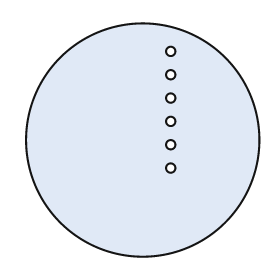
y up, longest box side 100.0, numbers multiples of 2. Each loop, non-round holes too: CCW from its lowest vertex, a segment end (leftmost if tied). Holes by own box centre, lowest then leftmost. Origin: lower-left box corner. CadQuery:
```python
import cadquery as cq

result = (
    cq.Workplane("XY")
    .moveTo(50.0, 50.0)
    .circle(50.0)
    .moveTo(62.0, 38.0)
    .circle(2.0)
    .moveTo(62.0, 48.0)
    .circle(2.0)
    .moveTo(62.0, 58.0)
    .circle(2.0)
    .moveTo(62.0, 68.0)
    .circle(2.0)
    .moveTo(62.0, 78.0)
    .circle(2.0)
    .moveTo(62.0, 88.0)
    .circle(2.0)
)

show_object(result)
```